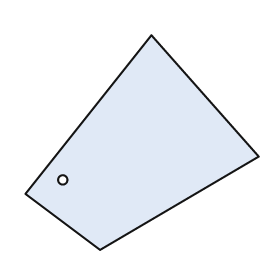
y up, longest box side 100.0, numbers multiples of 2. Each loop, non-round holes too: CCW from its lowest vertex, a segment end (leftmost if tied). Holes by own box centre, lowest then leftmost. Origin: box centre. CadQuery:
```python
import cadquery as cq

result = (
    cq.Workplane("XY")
    .moveTo(-18.0, -46.0)
    .lineTo(50.0, -6.0)
    .lineTo(4.0, 46.0)
    .lineTo(-50.0, -22.0)
    .close()
    .moveTo(-34.0, -16.0)
    .circle(2.0)
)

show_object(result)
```